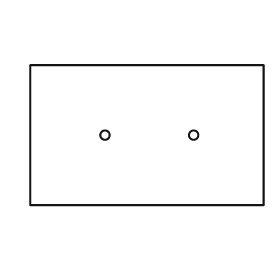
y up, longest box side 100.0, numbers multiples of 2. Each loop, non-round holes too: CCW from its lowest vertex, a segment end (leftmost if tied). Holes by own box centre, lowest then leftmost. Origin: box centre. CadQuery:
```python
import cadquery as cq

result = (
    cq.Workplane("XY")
    .moveTo(-50.0, -30.0)
    .lineTo(50.0, -30.0)
    .lineTo(50.0, 30.0)
    .lineTo(-50.0, 30.0)
    .close()
    .moveTo(-18.0, 0.0)
    .circle(2.0)
    .moveTo(20.0, 0.0)
    .circle(2.0)
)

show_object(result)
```